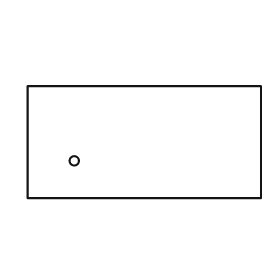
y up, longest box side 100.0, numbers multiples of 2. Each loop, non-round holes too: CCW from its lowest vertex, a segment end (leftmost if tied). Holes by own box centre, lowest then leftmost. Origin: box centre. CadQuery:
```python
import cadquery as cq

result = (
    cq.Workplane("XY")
    .moveTo(-50.0, -24.0)
    .lineTo(50.0, -24.0)
    .lineTo(50.0, 24.0)
    .lineTo(-50.0, 24.0)
    .close()
    .moveTo(-30.0, -8.0)
    .circle(2.0)
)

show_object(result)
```